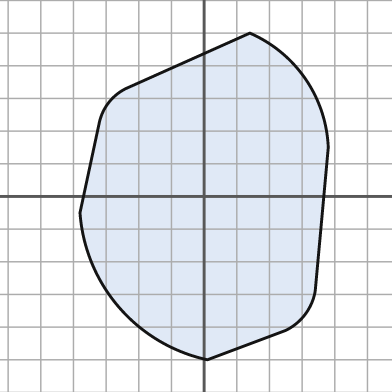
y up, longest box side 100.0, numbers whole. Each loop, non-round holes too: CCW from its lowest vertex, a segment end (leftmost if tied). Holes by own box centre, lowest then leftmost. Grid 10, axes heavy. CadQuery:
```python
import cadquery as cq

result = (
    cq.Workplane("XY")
    .moveTo(1.0, -50.0)
    .lineTo(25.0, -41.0)
    .threePointArc((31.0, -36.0), (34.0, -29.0))
    .lineTo(38.0, 15.0)
    .threePointArc((31.0, 36.0), (14.0, 50.0))
    .lineTo(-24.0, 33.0)
    .threePointArc((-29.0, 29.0), (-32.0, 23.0))
    .lineTo(-38.0, -5.0)
    .threePointArc((-26.0, -34.0), (1.0, -50.0))
    .close()
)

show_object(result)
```